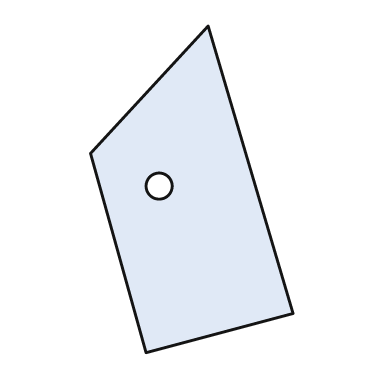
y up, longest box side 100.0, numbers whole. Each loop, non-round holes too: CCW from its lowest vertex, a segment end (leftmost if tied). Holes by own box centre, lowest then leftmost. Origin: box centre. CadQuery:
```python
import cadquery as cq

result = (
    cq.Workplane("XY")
    .moveTo(-14.0, -50.0)
    .lineTo(31.0, -38.0)
    .lineTo(5.0, 50.0)
    .lineTo(-31.0, 11.0)
    .close()
    .moveTo(-10.0, 1.0)
    .circle(4.0)
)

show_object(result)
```